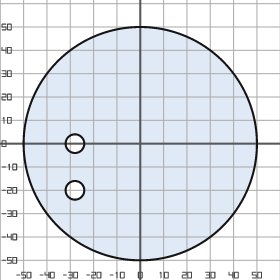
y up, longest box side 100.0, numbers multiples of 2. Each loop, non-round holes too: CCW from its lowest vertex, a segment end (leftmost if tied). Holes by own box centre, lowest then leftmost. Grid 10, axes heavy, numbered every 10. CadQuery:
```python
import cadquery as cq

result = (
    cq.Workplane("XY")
    .moveTo(0.0, 0.0)
    .circle(50.0)
    .moveTo(-28.0, -20.0)
    .circle(4.0)
    .moveTo(-28.0, 0.0)
    .circle(4.0)
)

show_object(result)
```